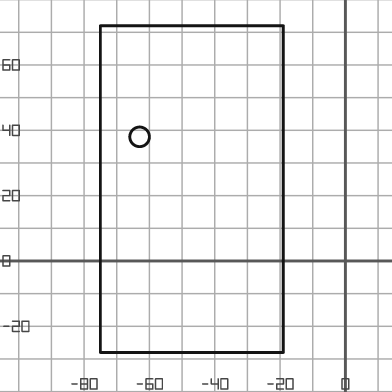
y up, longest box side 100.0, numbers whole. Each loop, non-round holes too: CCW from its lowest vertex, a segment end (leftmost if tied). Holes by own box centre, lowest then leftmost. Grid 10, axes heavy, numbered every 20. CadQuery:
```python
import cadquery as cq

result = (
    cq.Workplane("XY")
    .moveTo(-75.0, -28.0)
    .lineTo(-19.0, -28.0)
    .lineTo(-19.0, 72.0)
    .lineTo(-75.0, 72.0)
    .close()
    .moveTo(-63.0, 38.0)
    .circle(3.0)
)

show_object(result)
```